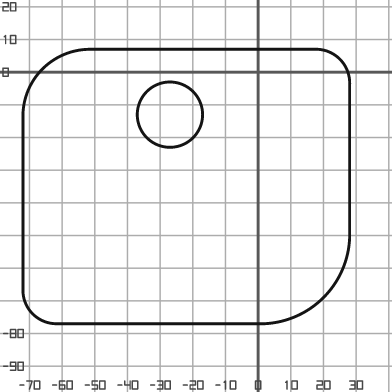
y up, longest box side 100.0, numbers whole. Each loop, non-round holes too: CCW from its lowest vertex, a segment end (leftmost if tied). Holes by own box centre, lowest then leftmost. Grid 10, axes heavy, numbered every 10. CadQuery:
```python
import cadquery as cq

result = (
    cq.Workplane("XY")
    .moveTo(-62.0, -77.0)
    .lineTo(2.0, -77.0)
    .threePointArc((20.0, -69.0), (28.0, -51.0))
    .lineTo(28.0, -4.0)
    .threePointArc((25.0, 4.0), (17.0, 7.0))
    .lineTo(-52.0, 7.0)
    .threePointArc((-66.0, 1.0), (-72.0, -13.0))
    .lineTo(-72.0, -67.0)
    .threePointArc((-69.0, -74.0), (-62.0, -77.0))
    .close()
    .moveTo(-27.0, -13.0)
    .circle(10.0)
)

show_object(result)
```